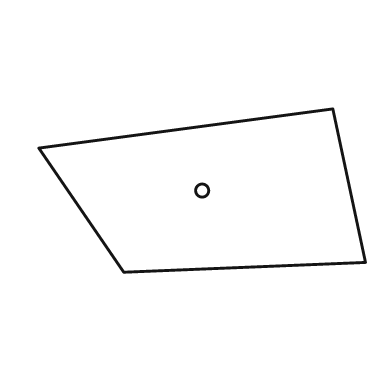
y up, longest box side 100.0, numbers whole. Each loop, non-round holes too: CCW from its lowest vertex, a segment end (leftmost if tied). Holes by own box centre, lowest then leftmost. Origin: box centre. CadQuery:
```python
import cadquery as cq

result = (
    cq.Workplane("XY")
    .moveTo(-24.0, -25.0)
    .lineTo(50.0, -22.0)
    .lineTo(40.0, 25.0)
    .lineTo(-50.0, 13.0)
    .close()
    .moveTo(0.0, 0.0)
    .circle(2.0)
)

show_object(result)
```